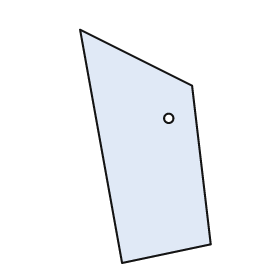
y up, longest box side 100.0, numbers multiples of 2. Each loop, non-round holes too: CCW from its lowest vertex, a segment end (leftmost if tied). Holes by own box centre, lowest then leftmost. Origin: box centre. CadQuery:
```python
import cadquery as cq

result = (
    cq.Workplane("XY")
    .moveTo(-10.0, -50.0)
    .lineTo(28.0, -42.0)
    .lineTo(20.0, 26.0)
    .lineTo(-28.0, 50.0)
    .close()
    .moveTo(10.0, 12.0)
    .circle(2.0)
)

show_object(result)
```